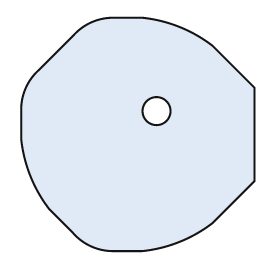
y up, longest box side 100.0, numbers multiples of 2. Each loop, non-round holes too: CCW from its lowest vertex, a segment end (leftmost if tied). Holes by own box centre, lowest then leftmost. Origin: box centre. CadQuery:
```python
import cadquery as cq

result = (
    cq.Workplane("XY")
    .moveTo(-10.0, -50.0)
    .lineTo(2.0, -50.0)
    .threePointArc((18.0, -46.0), (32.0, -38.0))
    .lineTo(50.0, -20.0)
    .lineTo(50.0, 20.0)
    .lineTo(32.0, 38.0)
    .threePointArc((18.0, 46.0), (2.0, 50.0))
    .lineTo(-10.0, 50.0)
    .threePointArc((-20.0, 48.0), (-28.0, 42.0))
    .lineTo(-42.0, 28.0)
    .threePointArc((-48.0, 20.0), (-50.0, 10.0))
    .lineTo(-50.0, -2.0)
    .threePointArc((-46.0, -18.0), (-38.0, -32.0))
    .lineTo(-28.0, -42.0)
    .threePointArc((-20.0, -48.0), (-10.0, -50.0))
    .close()
    .moveTo(8.0, 10.0)
    .circle(6.0)
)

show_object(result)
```